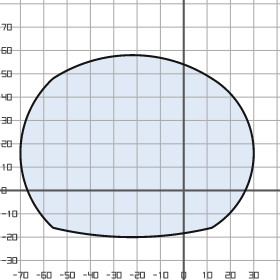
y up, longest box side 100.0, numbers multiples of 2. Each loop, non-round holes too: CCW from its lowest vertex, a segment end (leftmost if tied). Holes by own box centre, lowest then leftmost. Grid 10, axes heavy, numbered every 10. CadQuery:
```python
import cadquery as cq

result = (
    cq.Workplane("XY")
    .moveTo(-56.0, -16.0)
    .threePointArc((-22.0, -20.0), (12.0, -16.0))
    .threePointArc((30.0, 16.0), (12.0, 48.0))
    .threePointArc((-22.0, 58.0), (-56.0, 48.0))
    .threePointArc((-70.0, 16.0), (-56.0, -16.0))
    .close()
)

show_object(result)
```